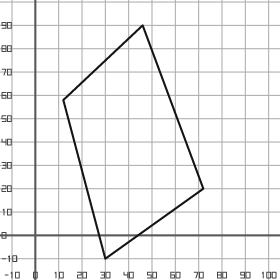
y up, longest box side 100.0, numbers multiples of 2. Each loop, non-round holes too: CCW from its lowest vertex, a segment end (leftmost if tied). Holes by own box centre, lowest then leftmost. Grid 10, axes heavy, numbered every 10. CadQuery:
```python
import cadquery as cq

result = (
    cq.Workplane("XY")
    .moveTo(30.0, -10.0)
    .lineTo(72.0, 20.0)
    .lineTo(46.0, 90.0)
    .lineTo(12.0, 58.0)
    .close()
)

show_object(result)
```